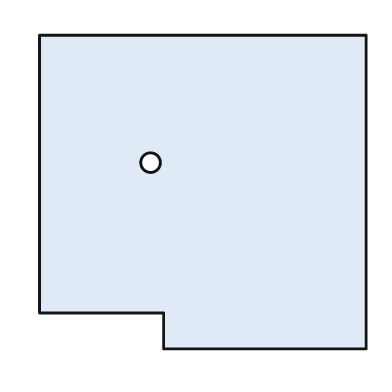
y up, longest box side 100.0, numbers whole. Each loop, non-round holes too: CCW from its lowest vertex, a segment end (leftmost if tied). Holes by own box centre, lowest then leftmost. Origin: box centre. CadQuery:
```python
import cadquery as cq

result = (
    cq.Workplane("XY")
    .moveTo(-12.0, -48.0)
    .lineTo(50.0, -48.0)
    .lineTo(50.0, 48.0)
    .lineTo(-50.0, 48.0)
    .lineTo(-50.0, -37.0)
    .lineTo(-12.0, -37.0)
    .close()
    .moveTo(-16.0, 9.0)
    .circle(3.0)
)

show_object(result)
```